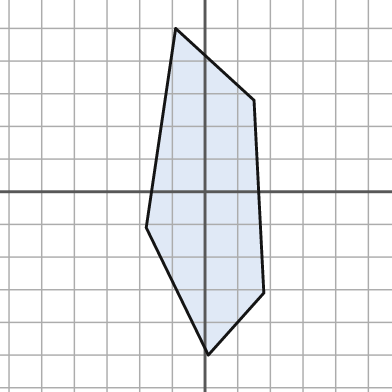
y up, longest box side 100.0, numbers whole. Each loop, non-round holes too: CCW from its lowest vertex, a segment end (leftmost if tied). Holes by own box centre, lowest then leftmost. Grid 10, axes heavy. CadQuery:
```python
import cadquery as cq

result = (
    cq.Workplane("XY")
    .moveTo(1.0, -50.0)
    .lineTo(18.0, -31.0)
    .lineTo(15.0, 28.0)
    .lineTo(-9.0, 50.0)
    .lineTo(-18.0, -11.0)
    .close()
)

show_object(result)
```